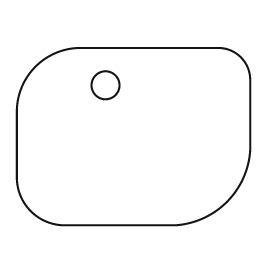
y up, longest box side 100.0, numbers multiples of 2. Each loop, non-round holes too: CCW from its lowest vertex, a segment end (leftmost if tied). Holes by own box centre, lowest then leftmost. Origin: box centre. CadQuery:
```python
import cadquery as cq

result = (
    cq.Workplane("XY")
    .moveTo(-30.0, -38.0)
    .lineTo(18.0, -38.0)
    .threePointArc((40.0, -28.0), (50.0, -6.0))
    .lineTo(50.0, 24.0)
    .threePointArc((46.0, 34.0), (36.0, 38.0))
    .lineTo(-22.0, 38.0)
    .threePointArc((-42.0, 30.0), (-50.0, 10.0))
    .lineTo(-50.0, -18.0)
    .threePointArc((-44.0, -32.0), (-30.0, -38.0))
    .close()
    .moveTo(-12.0, 22.0)
    .circle(6.0)
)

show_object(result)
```